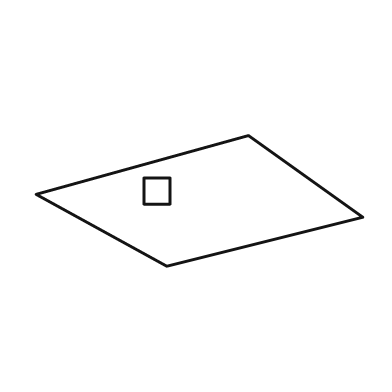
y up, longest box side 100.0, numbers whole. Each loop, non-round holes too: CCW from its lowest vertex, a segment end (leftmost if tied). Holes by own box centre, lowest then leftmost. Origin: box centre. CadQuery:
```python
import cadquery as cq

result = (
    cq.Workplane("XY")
    .moveTo(-10.0, -20.0)
    .lineTo(50.0, -5.0)
    .lineTo(15.0, 20.0)
    .lineTo(-50.0, 2.0)
    .close()
    .moveTo(-17.0, -1.0)
    .lineTo(-9.0, -1.0)
    .lineTo(-9.0, 7.0)
    .lineTo(-17.0, 7.0)
    .close()
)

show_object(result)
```